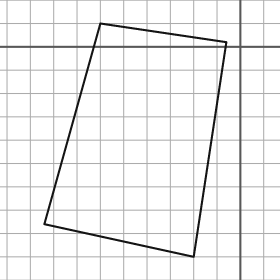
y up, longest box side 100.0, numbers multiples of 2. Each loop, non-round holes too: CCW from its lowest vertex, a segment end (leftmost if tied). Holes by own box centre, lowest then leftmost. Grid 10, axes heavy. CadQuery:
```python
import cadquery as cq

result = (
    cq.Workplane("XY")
    .moveTo(-20.0, -90.0)
    .lineTo(-6.0, 2.0)
    .lineTo(-60.0, 10.0)
    .lineTo(-84.0, -76.0)
    .close()
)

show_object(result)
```